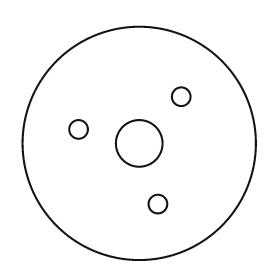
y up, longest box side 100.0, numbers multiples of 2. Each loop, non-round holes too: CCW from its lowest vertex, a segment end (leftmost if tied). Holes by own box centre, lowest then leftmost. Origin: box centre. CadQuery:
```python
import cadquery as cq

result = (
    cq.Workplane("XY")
    .moveTo(0.0, 0.0)
    .circle(50.0)
    .moveTo(8.0, -26.0)
    .circle(4.0)
    .moveTo(0.0, 0.0)
    .circle(10.0)
    .moveTo(-26.0, 6.0)
    .circle(4.0)
    .moveTo(18.0, 20.0)
    .circle(4.0)
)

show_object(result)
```